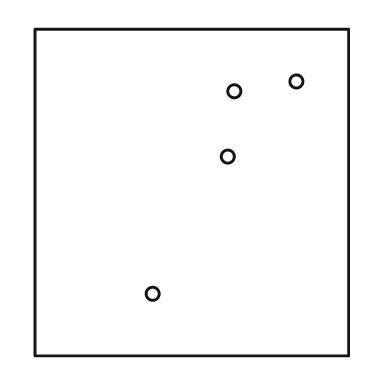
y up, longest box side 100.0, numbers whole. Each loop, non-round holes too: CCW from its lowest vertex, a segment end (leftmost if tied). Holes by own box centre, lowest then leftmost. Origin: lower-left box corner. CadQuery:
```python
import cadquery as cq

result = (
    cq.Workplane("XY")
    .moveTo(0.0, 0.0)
    .lineTo(96.0, 0.0)
    .lineTo(96.0, 100.0)
    .lineTo(0.0, 100.0)
    .close()
    .moveTo(36.0, 19.0)
    .circle(2.0)
    .moveTo(59.0, 61.0)
    .circle(2.0)
    .moveTo(61.0, 81.0)
    .circle(2.0)
    .moveTo(80.0, 84.0)
    .circle(2.0)
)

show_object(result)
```